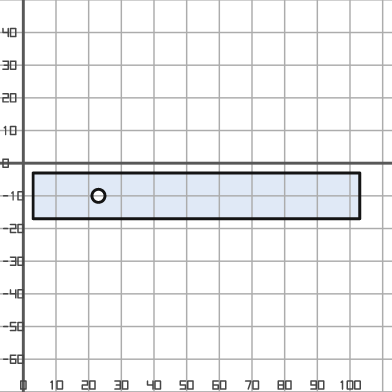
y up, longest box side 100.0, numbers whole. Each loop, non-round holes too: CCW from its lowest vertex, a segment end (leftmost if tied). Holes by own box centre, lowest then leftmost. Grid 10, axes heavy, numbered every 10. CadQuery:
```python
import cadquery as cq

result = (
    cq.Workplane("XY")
    .moveTo(3.0, -17.0)
    .lineTo(103.0, -17.0)
    .lineTo(103.0, -3.0)
    .lineTo(3.0, -3.0)
    .close()
    .moveTo(23.0, -10.0)
    .circle(2.0)
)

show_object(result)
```